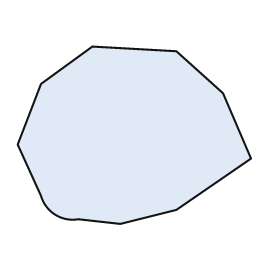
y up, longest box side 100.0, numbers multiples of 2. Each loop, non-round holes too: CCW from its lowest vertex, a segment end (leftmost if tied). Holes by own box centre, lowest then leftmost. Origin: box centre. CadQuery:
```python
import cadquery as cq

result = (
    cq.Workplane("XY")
    .moveTo(-6.0, -38.0)
    .lineTo(18.0, -32.0)
    .lineTo(50.0, -10.0)
    .lineTo(38.0, 18.0)
    .lineTo(18.0, 36.0)
    .lineTo(-18.0, 38.0)
    .lineTo(-40.0, 22.0)
    .lineTo(-50.0, -4.0)
    .lineTo(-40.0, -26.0)
    .threePointArc((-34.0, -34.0), (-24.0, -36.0))
    .close()
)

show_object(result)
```